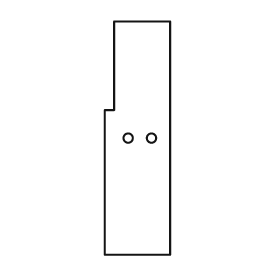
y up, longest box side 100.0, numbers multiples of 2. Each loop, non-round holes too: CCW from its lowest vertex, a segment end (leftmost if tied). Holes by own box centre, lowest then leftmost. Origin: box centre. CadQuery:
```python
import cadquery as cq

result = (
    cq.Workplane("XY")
    .moveTo(-14.0, -50.0)
    .lineTo(14.0, -50.0)
    .lineTo(14.0, 50.0)
    .lineTo(-10.0, 50.0)
    .lineTo(-10.0, 12.0)
    .lineTo(-14.0, 12.0)
    .close()
    .moveTo(-4.0, 0.0)
    .circle(2.0)
    .moveTo(6.0, 0.0)
    .circle(2.0)
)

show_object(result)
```